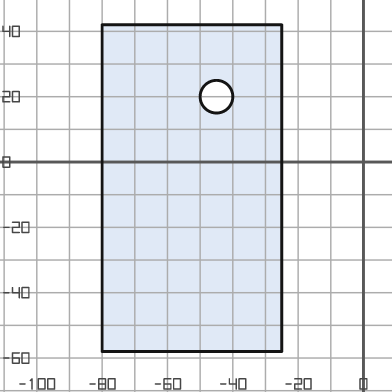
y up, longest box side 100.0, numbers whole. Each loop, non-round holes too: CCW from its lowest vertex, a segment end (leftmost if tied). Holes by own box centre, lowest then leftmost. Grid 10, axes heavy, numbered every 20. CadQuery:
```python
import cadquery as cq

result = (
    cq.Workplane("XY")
    .moveTo(-80.0, -58.0)
    .lineTo(-25.0, -58.0)
    .lineTo(-25.0, 42.0)
    .lineTo(-80.0, 42.0)
    .close()
    .moveTo(-45.0, 20.0)
    .circle(5.0)
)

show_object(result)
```